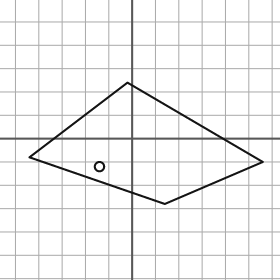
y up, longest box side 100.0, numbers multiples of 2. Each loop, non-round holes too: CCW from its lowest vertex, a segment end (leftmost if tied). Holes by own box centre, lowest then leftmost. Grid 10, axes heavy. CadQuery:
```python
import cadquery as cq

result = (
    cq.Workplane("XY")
    .moveTo(14.0, -28.0)
    .lineTo(56.0, -10.0)
    .lineTo(-2.0, 24.0)
    .lineTo(-44.0, -8.0)
    .close()
    .moveTo(-14.0, -12.0)
    .circle(2.0)
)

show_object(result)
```